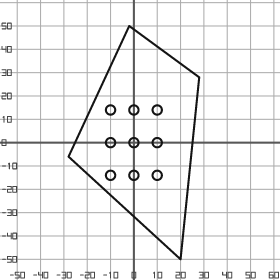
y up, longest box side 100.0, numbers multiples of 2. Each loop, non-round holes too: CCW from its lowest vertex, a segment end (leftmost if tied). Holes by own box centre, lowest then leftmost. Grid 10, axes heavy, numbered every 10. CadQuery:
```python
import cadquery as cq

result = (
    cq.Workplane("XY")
    .moveTo(20.0, -50.0)
    .lineTo(28.0, 28.0)
    .lineTo(-2.0, 50.0)
    .lineTo(-28.0, -6.0)
    .close()
    .moveTo(-10.0, -14.0)
    .circle(2.0)
    .moveTo(0.0, -14.0)
    .circle(2.0)
    .moveTo(10.0, -14.0)
    .circle(2.0)
    .moveTo(-10.0, 0.0)
    .circle(2.0)
    .moveTo(0.0, 0.0)
    .circle(2.0)
    .moveTo(10.0, 0.0)
    .circle(2.0)
    .moveTo(-10.0, 14.0)
    .circle(2.0)
    .moveTo(0.0, 14.0)
    .circle(2.0)
    .moveTo(10.0, 14.0)
    .circle(2.0)
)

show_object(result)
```